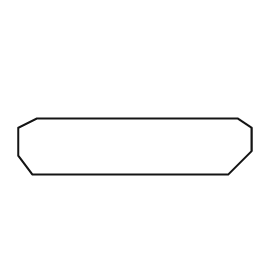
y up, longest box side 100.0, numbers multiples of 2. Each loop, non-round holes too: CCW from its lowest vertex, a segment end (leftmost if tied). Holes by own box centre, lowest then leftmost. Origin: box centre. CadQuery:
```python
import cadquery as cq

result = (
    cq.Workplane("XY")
    .moveTo(-44.0, -12.0)
    .lineTo(40.0, -12.0)
    .lineTo(50.0, -2.0)
    .lineTo(50.0, 8.0)
    .lineTo(44.0, 12.0)
    .lineTo(-42.0, 12.0)
    .lineTo(-50.0, 8.0)
    .lineTo(-50.0, -4.0)
    .close()
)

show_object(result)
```